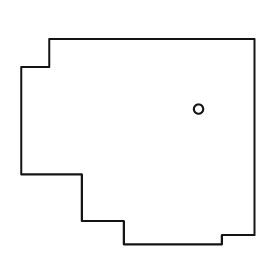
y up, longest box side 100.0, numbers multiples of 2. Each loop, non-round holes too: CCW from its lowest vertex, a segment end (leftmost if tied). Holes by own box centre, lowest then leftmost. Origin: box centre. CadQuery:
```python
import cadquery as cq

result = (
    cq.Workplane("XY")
    .moveTo(-6.0, -44.0)
    .lineTo(36.0, -44.0)
    .lineTo(36.0, -40.0)
    .lineTo(50.0, -40.0)
    .lineTo(50.0, 44.0)
    .lineTo(-38.0, 44.0)
    .lineTo(-38.0, 32.0)
    .lineTo(-50.0, 32.0)
    .lineTo(-50.0, -14.0)
    .lineTo(-24.0, -14.0)
    .lineTo(-24.0, -34.0)
    .lineTo(-6.0, -34.0)
    .close()
    .moveTo(26.0, 14.0)
    .circle(2.0)
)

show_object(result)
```